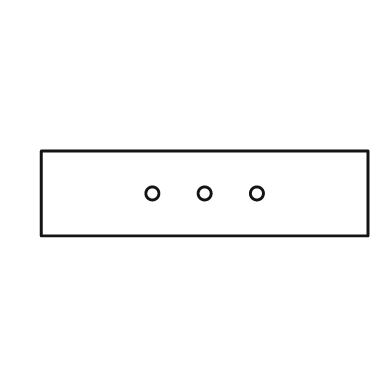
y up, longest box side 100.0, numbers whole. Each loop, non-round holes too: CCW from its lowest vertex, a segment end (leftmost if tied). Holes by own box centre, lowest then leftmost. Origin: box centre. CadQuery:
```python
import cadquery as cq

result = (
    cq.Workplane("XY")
    .moveTo(-50.0, -13.0)
    .lineTo(50.0, -13.0)
    .lineTo(50.0, 13.0)
    .lineTo(-50.0, 13.0)
    .close()
    .moveTo(-16.0, 0.0)
    .circle(2.0)
    .moveTo(0.0, 0.0)
    .circle(2.0)
    .moveTo(16.0, 0.0)
    .circle(2.0)
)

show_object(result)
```